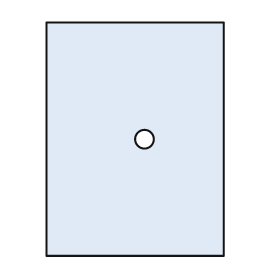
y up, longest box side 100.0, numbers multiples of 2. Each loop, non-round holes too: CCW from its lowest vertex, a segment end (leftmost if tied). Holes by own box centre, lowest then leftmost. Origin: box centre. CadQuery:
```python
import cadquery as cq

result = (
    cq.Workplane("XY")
    .moveTo(-38.0, -50.0)
    .lineTo(38.0, -50.0)
    .lineTo(38.0, 50.0)
    .lineTo(-38.0, 50.0)
    .close()
    .moveTo(4.0, 0.0)
    .circle(4.0)
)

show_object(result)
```